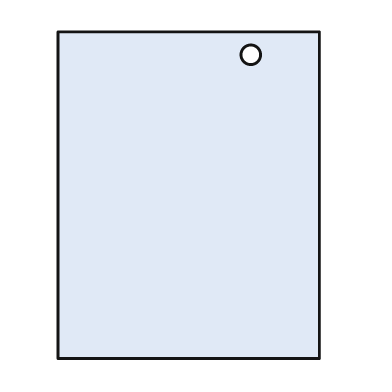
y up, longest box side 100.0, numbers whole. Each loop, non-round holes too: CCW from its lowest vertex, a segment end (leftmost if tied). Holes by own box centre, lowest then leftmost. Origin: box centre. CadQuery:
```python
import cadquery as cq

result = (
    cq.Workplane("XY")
    .moveTo(-40.0, -50.0)
    .lineTo(40.0, -50.0)
    .lineTo(40.0, 50.0)
    .lineTo(-40.0, 50.0)
    .close()
    .moveTo(19.0, 43.0)
    .circle(3.0)
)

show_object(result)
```